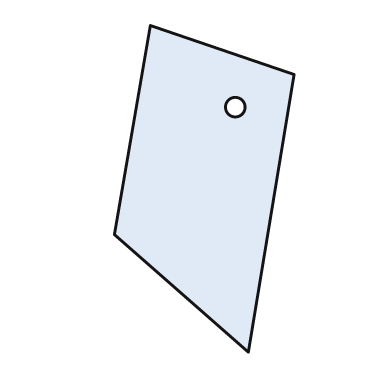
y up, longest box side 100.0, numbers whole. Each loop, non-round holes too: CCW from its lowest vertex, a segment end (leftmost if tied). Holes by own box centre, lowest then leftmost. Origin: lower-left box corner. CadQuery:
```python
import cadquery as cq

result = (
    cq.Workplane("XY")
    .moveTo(41.0, 0.0)
    .lineTo(55.0, 85.0)
    .lineTo(11.0, 100.0)
    .lineTo(0.0, 36.0)
    .close()
    .moveTo(37.0, 75.0)
    .circle(3.0)
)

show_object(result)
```